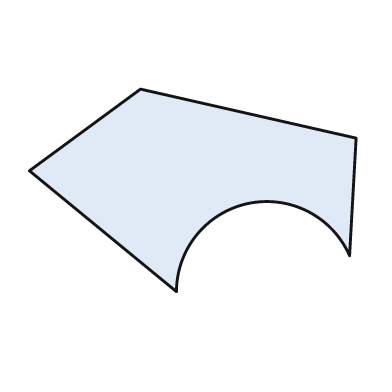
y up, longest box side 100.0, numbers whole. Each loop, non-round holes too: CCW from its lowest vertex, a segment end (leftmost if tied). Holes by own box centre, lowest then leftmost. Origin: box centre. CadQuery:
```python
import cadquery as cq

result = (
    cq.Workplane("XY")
    .moveTo(-5.0, -31.0)
    .threePointArc((17.0, -4.0), (48.0, -20.0))
    .lineTo(50.0, 16.0)
    .lineTo(-16.0, 31.0)
    .lineTo(-50.0, 6.0)
    .close()
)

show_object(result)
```